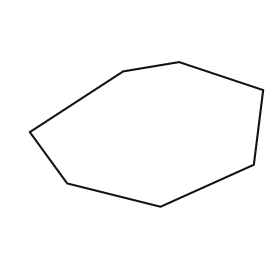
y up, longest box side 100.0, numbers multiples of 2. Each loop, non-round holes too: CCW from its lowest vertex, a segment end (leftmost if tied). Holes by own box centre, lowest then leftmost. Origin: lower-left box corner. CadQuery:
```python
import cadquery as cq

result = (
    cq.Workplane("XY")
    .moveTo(56.0, 0.0)
    .lineTo(96.0, 18.0)
    .lineTo(100.0, 50.0)
    .lineTo(64.0, 62.0)
    .lineTo(40.0, 58.0)
    .lineTo(0.0, 32.0)
    .lineTo(16.0, 10.0)
    .close()
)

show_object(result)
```